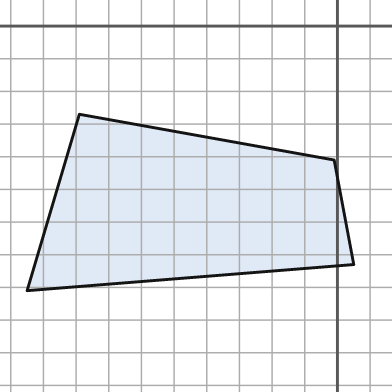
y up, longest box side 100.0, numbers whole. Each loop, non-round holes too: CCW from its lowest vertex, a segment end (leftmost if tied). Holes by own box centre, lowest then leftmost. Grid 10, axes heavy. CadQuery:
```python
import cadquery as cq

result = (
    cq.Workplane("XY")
    .moveTo(-95.0, -81.0)
    .lineTo(5.0, -73.0)
    .lineTo(-1.0, -41.0)
    .lineTo(-79.0, -27.0)
    .close()
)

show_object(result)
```